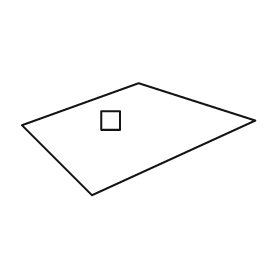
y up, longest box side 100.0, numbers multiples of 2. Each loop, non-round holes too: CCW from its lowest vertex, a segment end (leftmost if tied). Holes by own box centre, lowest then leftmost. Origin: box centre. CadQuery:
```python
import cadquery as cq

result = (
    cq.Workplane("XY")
    .moveTo(-20.0, -24.0)
    .lineTo(50.0, 8.0)
    .lineTo(0.0, 24.0)
    .lineTo(-50.0, 6.0)
    .close()
    .moveTo(-16.0, 4.0)
    .lineTo(-8.0, 4.0)
    .lineTo(-8.0, 12.0)
    .lineTo(-16.0, 12.0)
    .close()
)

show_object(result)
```